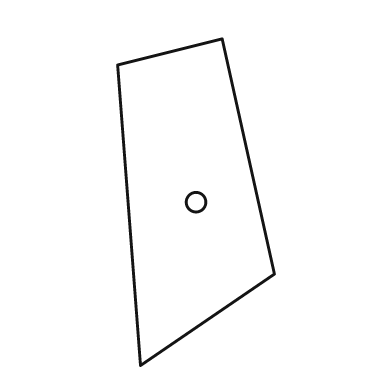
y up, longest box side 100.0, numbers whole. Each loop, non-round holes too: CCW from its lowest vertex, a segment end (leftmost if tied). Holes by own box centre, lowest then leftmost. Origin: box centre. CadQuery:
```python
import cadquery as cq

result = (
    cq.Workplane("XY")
    .moveTo(-17.0, -50.0)
    .lineTo(24.0, -22.0)
    .lineTo(8.0, 50.0)
    .lineTo(-24.0, 42.0)
    .close()
    .moveTo(0.0, 0.0)
    .circle(3.0)
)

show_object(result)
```